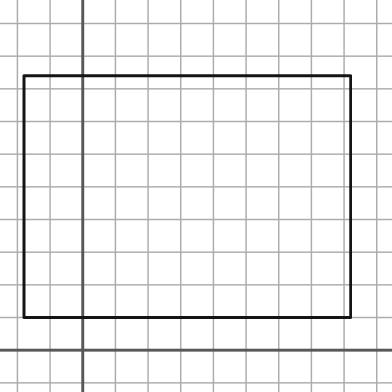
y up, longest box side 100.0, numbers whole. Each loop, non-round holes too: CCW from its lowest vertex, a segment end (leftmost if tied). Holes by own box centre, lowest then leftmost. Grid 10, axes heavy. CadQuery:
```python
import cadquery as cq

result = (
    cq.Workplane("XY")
    .moveTo(-18.0, 10.0)
    .lineTo(82.0, 10.0)
    .lineTo(82.0, 84.0)
    .lineTo(-18.0, 84.0)
    .close()
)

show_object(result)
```